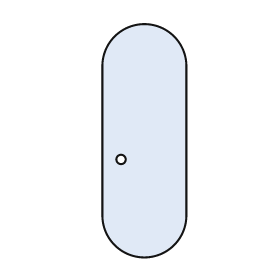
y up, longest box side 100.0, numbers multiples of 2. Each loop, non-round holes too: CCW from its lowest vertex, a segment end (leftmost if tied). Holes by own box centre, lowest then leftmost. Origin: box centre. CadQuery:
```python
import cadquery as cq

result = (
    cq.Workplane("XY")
    .moveTo(-18.0, -32.0)
    .threePointArc((0.0, -50.0), (18.0, -32.0))
    .lineTo(18.0, 32.0)
    .threePointArc((0.0, 50.0), (-18.0, 32.0))
    .close()
    .moveTo(-10.0, -8.0)
    .circle(2.0)
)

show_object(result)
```